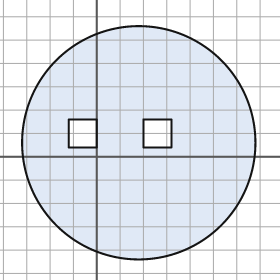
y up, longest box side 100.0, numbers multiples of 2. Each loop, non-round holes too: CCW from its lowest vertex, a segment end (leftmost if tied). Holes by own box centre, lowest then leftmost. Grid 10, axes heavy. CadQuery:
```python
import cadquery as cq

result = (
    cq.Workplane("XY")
    .moveTo(18.0, 6.0)
    .circle(50.0)
    .moveTo(-12.0, 4.0)
    .lineTo(0.0, 4.0)
    .lineTo(0.0, 16.0)
    .lineTo(-12.0, 16.0)
    .close()
    .moveTo(20.0, 4.0)
    .lineTo(32.0, 4.0)
    .lineTo(32.0, 16.0)
    .lineTo(20.0, 16.0)
    .close()
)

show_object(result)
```